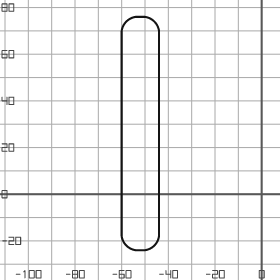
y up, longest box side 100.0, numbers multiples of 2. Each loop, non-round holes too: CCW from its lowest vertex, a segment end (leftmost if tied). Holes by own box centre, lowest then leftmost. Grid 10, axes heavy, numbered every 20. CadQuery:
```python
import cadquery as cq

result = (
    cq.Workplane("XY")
    .moveTo(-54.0, -24.0)
    .lineTo(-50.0, -24.0)
    .threePointArc((-46.0, -22.0), (-44.0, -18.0))
    .lineTo(-44.0, 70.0)
    .threePointArc((-46.0, 74.0), (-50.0, 76.0))
    .lineTo(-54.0, 76.0)
    .threePointArc((-58.0, 74.0), (-60.0, 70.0))
    .lineTo(-60.0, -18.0)
    .threePointArc((-58.0, -22.0), (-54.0, -24.0))
    .close()
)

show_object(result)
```